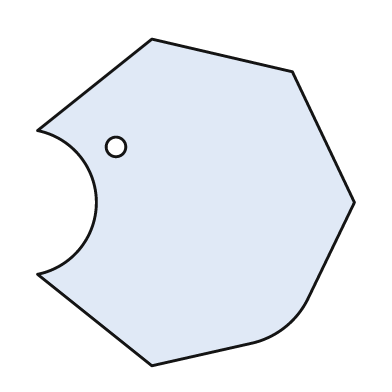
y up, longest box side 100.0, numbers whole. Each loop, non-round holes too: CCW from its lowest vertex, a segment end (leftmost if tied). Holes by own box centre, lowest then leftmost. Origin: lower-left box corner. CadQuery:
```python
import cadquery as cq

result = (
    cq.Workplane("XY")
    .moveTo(35.0, 0.0)
    .lineTo(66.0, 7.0)
    .threePointArc((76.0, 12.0), (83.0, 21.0))
    .lineTo(97.0, 50.0)
    .lineTo(78.0, 90.0)
    .lineTo(35.0, 100.0)
    .lineTo(0.0, 72.0)
    .threePointArc((18.0, 50.0), (0.0, 28.0))
    .close()
    .moveTo(24.0, 67.0)
    .circle(3.0)
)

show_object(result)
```